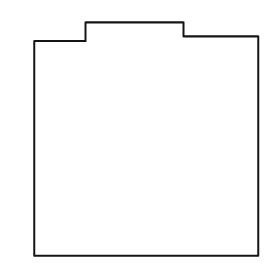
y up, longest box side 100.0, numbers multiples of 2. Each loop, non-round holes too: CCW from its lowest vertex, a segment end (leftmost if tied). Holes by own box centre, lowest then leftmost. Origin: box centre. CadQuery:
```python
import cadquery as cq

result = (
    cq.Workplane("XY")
    .moveTo(-48.0, -50.0)
    .lineTo(48.0, -50.0)
    .lineTo(48.0, 44.0)
    .lineTo(16.0, 44.0)
    .lineTo(16.0, 50.0)
    .lineTo(-26.0, 50.0)
    .lineTo(-26.0, 42.0)
    .lineTo(-48.0, 42.0)
    .close()
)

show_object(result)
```